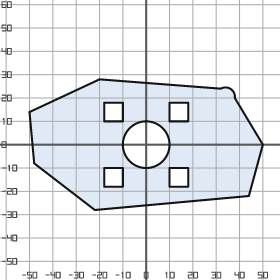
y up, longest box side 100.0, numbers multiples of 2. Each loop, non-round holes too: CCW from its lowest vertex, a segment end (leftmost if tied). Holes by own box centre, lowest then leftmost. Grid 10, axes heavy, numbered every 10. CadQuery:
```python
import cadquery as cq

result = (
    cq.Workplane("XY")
    .moveTo(-22.0, -28.0)
    .lineTo(44.0, -22.0)
    .lineTo(50.0, 0.0)
    .lineTo(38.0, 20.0)
    .threePointArc((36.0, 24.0), (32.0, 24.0))
    .lineTo(-20.0, 28.0)
    .lineTo(-50.0, 14.0)
    .lineTo(-48.0, -8.0)
    .close()
    .moveTo(-18.0, -18.0)
    .lineTo(-10.0, -18.0)
    .lineTo(-10.0, -10.0)
    .lineTo(-18.0, -10.0)
    .close()
    .moveTo(10.0, -18.0)
    .lineTo(18.0, -18.0)
    .lineTo(18.0, -10.0)
    .lineTo(10.0, -10.0)
    .close()
    .moveTo(0.0, 0.0)
    .circle(10.0)
    .moveTo(-18.0, 10.0)
    .lineTo(-10.0, 10.0)
    .lineTo(-10.0, 18.0)
    .lineTo(-18.0, 18.0)
    .close()
    .moveTo(10.0, 10.0)
    .lineTo(18.0, 10.0)
    .lineTo(18.0, 18.0)
    .lineTo(10.0, 18.0)
    .close()
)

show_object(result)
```